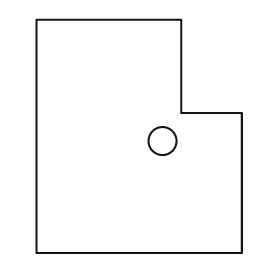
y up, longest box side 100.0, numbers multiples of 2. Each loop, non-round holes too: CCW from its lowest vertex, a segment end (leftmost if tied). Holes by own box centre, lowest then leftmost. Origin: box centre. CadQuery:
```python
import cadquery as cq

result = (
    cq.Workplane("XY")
    .moveTo(-44.0, -50.0)
    .lineTo(44.0, -50.0)
    .lineTo(44.0, 10.0)
    .lineTo(18.0, 10.0)
    .lineTo(18.0, 50.0)
    .lineTo(-44.0, 50.0)
    .close()
    .moveTo(10.0, -2.0)
    .circle(6.0)
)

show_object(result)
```